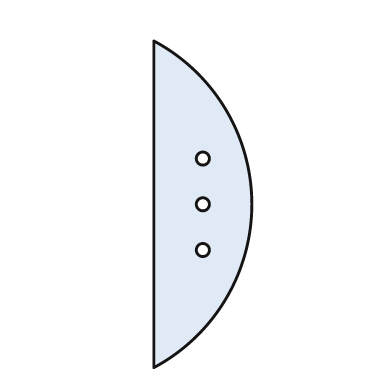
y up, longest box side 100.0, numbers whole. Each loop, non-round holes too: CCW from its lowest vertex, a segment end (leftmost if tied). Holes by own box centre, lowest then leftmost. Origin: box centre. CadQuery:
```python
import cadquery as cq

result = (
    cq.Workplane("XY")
    .moveTo(-15.0, -50.0)
    .threePointArc((15.0, 0.0), (-15.0, 50.0))
    .close()
    .moveTo(0.0, -14.0)
    .circle(2.0)
    .moveTo(0.0, 0.0)
    .circle(2.0)
    .moveTo(0.0, 14.0)
    .circle(2.0)
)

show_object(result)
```